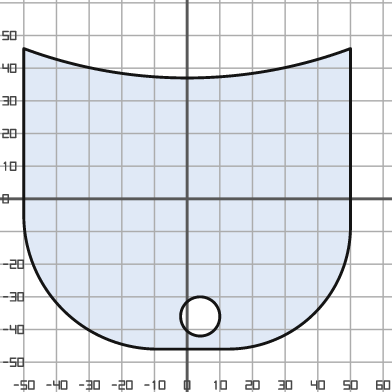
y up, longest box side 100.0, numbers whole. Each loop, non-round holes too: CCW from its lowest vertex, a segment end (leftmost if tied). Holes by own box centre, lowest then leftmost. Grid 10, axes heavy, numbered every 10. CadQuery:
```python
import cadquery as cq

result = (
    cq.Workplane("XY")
    .moveTo(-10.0, -46.0)
    .lineTo(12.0, -46.0)
    .threePointArc((39.0, -35.0), (50.0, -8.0))
    .lineTo(50.0, 46.0)
    .threePointArc((0.0, 37.0), (-50.0, 46.0))
    .lineTo(-50.0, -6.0)
    .threePointArc((-38.0, -34.0), (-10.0, -46.0))
    .close()
    .moveTo(4.0, -36.0)
    .circle(6.0)
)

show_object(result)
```